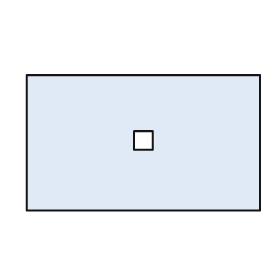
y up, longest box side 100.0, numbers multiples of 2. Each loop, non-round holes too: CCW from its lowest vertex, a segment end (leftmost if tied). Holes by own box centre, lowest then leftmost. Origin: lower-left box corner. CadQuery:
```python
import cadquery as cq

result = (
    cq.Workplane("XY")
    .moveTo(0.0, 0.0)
    .lineTo(100.0, 0.0)
    .lineTo(100.0, 58.0)
    .lineTo(0.0, 58.0)
    .close()
    .moveTo(46.0, 26.0)
    .lineTo(54.0, 26.0)
    .lineTo(54.0, 34.0)
    .lineTo(46.0, 34.0)
    .close()
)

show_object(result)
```